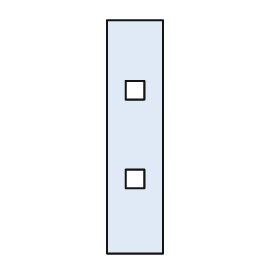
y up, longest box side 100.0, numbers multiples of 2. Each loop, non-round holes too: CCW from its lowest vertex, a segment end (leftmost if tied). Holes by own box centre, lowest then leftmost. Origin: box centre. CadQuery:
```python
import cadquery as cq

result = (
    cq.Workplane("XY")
    .moveTo(-12.0, -50.0)
    .lineTo(12.0, -50.0)
    .lineTo(12.0, 50.0)
    .lineTo(-12.0, 50.0)
    .close()
    .moveTo(-4.0, -22.0)
    .lineTo(4.0, -22.0)
    .lineTo(4.0, -14.0)
    .lineTo(-4.0, -14.0)
    .close()
    .moveTo(-4.0, 16.0)
    .lineTo(4.0, 16.0)
    .lineTo(4.0, 24.0)
    .lineTo(-4.0, 24.0)
    .close()
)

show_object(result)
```